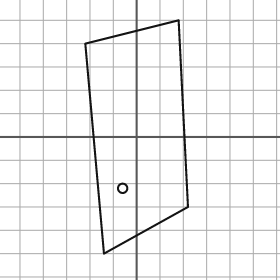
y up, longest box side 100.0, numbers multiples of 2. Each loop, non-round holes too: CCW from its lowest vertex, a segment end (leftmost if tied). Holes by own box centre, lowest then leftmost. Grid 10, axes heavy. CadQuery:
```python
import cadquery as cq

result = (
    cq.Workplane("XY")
    .moveTo(-14.0, -50.0)
    .lineTo(22.0, -30.0)
    .lineTo(18.0, 50.0)
    .lineTo(-22.0, 40.0)
    .close()
    .moveTo(-6.0, -22.0)
    .circle(2.0)
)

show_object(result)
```